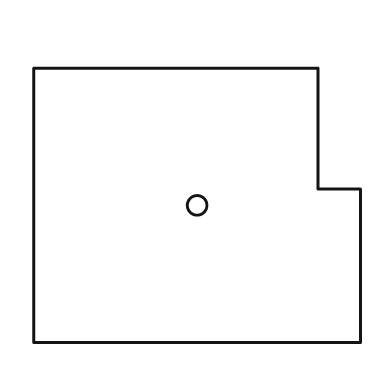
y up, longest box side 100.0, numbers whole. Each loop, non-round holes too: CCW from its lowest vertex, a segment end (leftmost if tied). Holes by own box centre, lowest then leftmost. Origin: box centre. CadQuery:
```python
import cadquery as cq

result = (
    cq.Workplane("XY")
    .moveTo(-50.0, -42.0)
    .lineTo(50.0, -42.0)
    .lineTo(50.0, 5.0)
    .lineTo(37.0, 5.0)
    .lineTo(37.0, 42.0)
    .lineTo(-50.0, 42.0)
    .close()
    .moveTo(0.0, 0.0)
    .circle(3.0)
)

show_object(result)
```